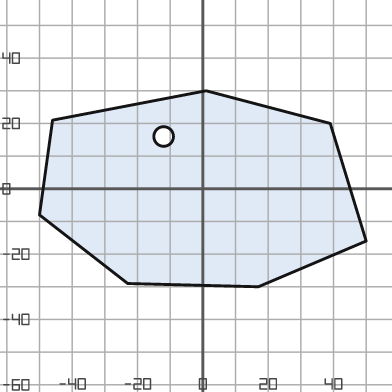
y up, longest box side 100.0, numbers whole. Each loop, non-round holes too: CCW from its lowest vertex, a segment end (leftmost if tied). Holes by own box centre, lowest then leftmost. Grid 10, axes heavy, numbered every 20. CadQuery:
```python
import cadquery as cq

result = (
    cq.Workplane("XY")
    .moveTo(17.0, -30.0)
    .lineTo(50.0, -16.0)
    .lineTo(39.0, 20.0)
    .lineTo(1.0, 30.0)
    .lineTo(-46.0, 21.0)
    .lineTo(-50.0, -8.0)
    .lineTo(-23.0, -29.0)
    .close()
    .moveTo(-12.0, 16.0)
    .circle(3.0)
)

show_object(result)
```